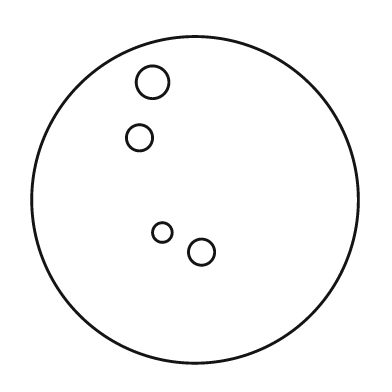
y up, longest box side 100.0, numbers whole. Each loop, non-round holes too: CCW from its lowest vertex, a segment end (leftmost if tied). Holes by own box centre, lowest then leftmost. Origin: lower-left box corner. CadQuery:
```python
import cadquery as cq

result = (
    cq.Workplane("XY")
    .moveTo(50.0, 50.0)
    .circle(50.0)
    .moveTo(52.0, 34.0)
    .circle(4.0)
    .moveTo(40.0, 40.0)
    .circle(3.0)
    .moveTo(33.0, 69.0)
    .circle(4.0)
    .moveTo(37.0, 86.0)
    .circle(5.0)
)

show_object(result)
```